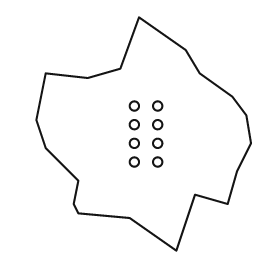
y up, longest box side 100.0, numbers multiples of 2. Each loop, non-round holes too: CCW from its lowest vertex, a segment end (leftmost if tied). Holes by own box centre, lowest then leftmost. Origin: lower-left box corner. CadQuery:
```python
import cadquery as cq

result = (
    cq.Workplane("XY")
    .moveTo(60.0, 0.0)
    .lineTo(68.0, 24.0)
    .lineTo(82.0, 20.0)
    .lineTo(86.0, 34.0)
    .lineTo(92.0, 46.0)
    .lineTo(90.0, 58.0)
    .lineTo(84.0, 66.0)
    .lineTo(70.0, 76.0)
    .lineTo(64.0, 86.0)
    .lineTo(44.0, 100.0)
    .lineTo(36.0, 78.0)
    .lineTo(22.0, 74.0)
    .lineTo(4.0, 76.0)
    .lineTo(0.0, 56.0)
    .lineTo(4.0, 44.0)
    .lineTo(18.0, 30.0)
    .lineTo(16.0, 20.0)
    .lineTo(18.0, 16.0)
    .lineTo(40.0, 14.0)
    .close()
    .moveTo(42.0, 38.0)
    .circle(2.0)
    .moveTo(52.0, 38.0)
    .circle(2.0)
    .moveTo(42.0, 46.0)
    .circle(2.0)
    .moveTo(52.0, 46.0)
    .circle(2.0)
    .moveTo(42.0, 54.0)
    .circle(2.0)
    .moveTo(52.0, 54.0)
    .circle(2.0)
    .moveTo(42.0, 62.0)
    .circle(2.0)
    .moveTo(52.0, 62.0)
    .circle(2.0)
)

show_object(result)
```